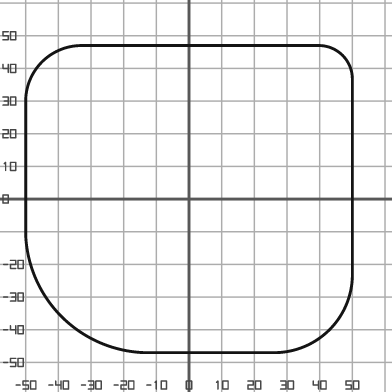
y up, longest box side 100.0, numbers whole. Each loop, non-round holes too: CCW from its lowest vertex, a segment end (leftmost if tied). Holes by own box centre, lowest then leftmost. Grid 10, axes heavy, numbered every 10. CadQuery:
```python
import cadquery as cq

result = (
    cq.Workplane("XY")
    .moveTo(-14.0, -47.0)
    .lineTo(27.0, -47.0)
    .threePointArc((43.0, -40.0), (50.0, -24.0))
    .lineTo(50.0, 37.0)
    .threePointArc((47.0, 44.0), (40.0, 47.0))
    .lineTo(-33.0, 47.0)
    .threePointArc((-45.0, 42.0), (-50.0, 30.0))
    .lineTo(-50.0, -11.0)
    .threePointArc((-39.0, -36.0), (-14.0, -47.0))
    .close()
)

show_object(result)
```